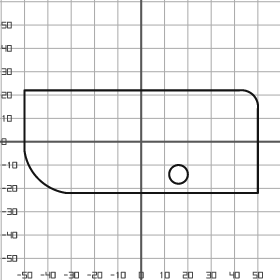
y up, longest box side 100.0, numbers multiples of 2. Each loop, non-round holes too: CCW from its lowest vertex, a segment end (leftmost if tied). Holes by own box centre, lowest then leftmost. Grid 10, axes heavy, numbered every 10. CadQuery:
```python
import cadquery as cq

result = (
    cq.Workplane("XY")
    .moveTo(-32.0, -22.0)
    .lineTo(50.0, -22.0)
    .lineTo(50.0, 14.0)
    .threePointArc((48.0, 20.0), (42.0, 22.0))
    .lineTo(-50.0, 22.0)
    .lineTo(-50.0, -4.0)
    .threePointArc((-44.0, -16.0), (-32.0, -22.0))
    .close()
    .moveTo(16.0, -14.0)
    .circle(4.0)
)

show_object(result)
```